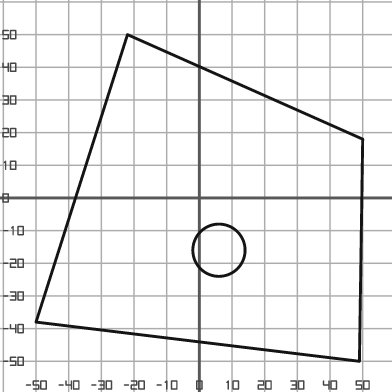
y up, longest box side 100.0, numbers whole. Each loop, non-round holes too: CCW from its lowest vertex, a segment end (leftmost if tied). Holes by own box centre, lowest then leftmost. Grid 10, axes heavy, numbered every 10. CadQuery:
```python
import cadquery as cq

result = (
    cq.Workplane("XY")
    .moveTo(49.0, -50.0)
    .lineTo(50.0, 18.0)
    .lineTo(-22.0, 50.0)
    .lineTo(-50.0, -38.0)
    .close()
    .moveTo(6.0, -16.0)
    .circle(8.0)
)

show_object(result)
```